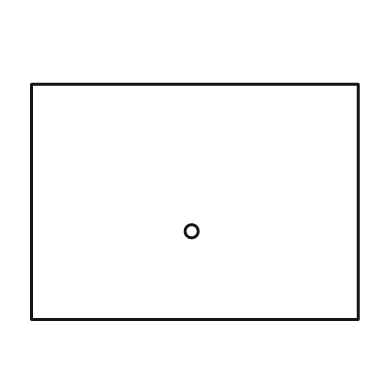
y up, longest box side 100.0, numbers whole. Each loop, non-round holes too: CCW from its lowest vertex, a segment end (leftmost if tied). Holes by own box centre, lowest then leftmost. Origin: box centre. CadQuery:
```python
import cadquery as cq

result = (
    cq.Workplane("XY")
    .moveTo(-50.0, -36.0)
    .lineTo(50.0, -36.0)
    .lineTo(50.0, 36.0)
    .lineTo(-50.0, 36.0)
    .close()
    .moveTo(-1.0, -9.0)
    .circle(2.0)
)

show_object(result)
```